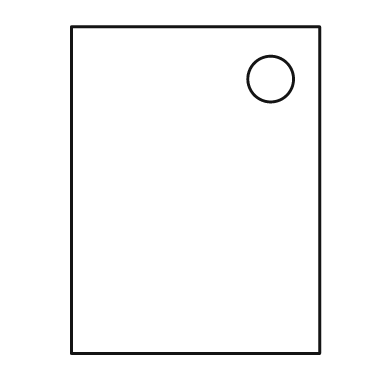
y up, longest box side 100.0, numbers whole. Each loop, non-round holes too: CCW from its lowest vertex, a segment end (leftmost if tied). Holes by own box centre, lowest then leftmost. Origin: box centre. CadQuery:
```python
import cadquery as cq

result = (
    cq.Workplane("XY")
    .moveTo(-38.0, -50.0)
    .lineTo(38.0, -50.0)
    .lineTo(38.0, 50.0)
    .lineTo(-38.0, 50.0)
    .close()
    .moveTo(23.0, 34.0)
    .circle(7.0)
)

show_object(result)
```